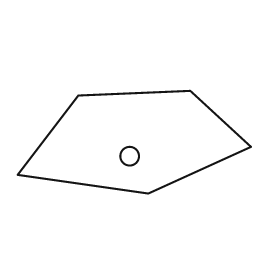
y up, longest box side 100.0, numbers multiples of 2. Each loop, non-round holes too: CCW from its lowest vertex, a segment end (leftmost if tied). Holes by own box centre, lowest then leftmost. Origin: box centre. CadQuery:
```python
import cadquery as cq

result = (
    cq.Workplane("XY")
    .moveTo(6.0, -22.0)
    .lineTo(50.0, -2.0)
    .lineTo(24.0, 22.0)
    .lineTo(-24.0, 20.0)
    .lineTo(-50.0, -14.0)
    .close()
    .moveTo(-2.0, -6.0)
    .circle(4.0)
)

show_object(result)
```